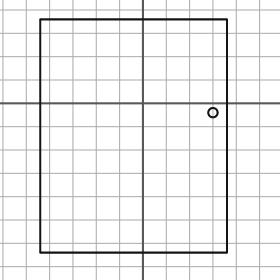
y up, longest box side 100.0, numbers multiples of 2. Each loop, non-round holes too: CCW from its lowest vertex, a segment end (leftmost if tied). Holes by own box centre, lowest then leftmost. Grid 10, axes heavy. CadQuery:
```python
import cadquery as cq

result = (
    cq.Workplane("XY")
    .moveTo(-44.0, -64.0)
    .lineTo(36.0, -64.0)
    .lineTo(36.0, 36.0)
    .lineTo(-44.0, 36.0)
    .close()
    .moveTo(30.0, -4.0)
    .circle(2.0)
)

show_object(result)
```